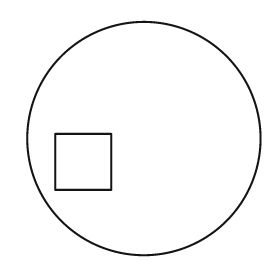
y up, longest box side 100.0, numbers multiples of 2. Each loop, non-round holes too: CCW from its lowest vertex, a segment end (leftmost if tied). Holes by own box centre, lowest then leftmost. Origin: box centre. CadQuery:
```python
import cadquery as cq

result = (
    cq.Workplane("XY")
    .moveTo(0.0, 0.0)
    .circle(50.0)
    .moveTo(-38.0, -22.0)
    .lineTo(-14.0, -22.0)
    .lineTo(-14.0, 2.0)
    .lineTo(-38.0, 2.0)
    .close()
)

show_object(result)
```